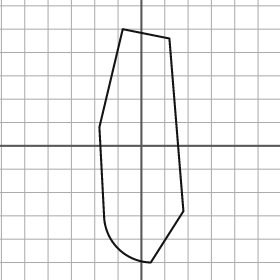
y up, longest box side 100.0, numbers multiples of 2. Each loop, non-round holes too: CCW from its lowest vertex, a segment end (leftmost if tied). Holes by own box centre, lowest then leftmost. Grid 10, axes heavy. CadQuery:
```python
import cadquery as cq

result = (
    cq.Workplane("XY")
    .moveTo(4.0, -50.0)
    .lineTo(18.0, -28.0)
    .lineTo(12.0, 46.0)
    .lineTo(-8.0, 50.0)
    .lineTo(-18.0, 8.0)
    .lineTo(-16.0, -30.0)
    .threePointArc((-10.0, -44.0), (4.0, -50.0))
    .close()
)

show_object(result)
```